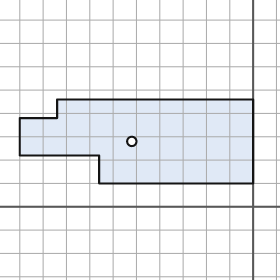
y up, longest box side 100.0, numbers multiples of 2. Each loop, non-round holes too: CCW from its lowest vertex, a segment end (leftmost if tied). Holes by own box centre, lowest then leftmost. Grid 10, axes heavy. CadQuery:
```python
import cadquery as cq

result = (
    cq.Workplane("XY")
    .moveTo(-66.0, 10.0)
    .lineTo(0.0, 10.0)
    .lineTo(0.0, 46.0)
    .lineTo(-84.0, 46.0)
    .lineTo(-84.0, 38.0)
    .lineTo(-100.0, 38.0)
    .lineTo(-100.0, 22.0)
    .lineTo(-66.0, 22.0)
    .close()
    .moveTo(-52.0, 28.0)
    .circle(2.0)
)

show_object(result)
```